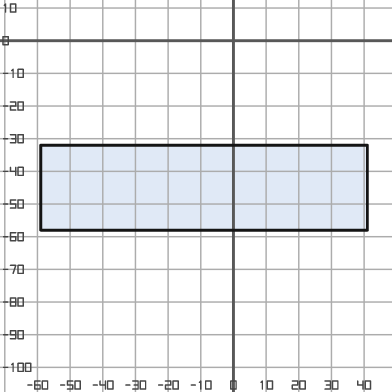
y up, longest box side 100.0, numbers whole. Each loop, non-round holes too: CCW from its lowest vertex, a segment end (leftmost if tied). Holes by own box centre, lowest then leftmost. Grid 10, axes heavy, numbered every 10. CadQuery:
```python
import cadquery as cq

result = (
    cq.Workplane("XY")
    .moveTo(-59.0, -58.0)
    .lineTo(41.0, -58.0)
    .lineTo(41.0, -32.0)
    .lineTo(-59.0, -32.0)
    .close()
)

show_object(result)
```